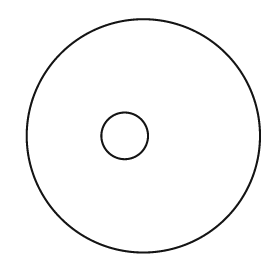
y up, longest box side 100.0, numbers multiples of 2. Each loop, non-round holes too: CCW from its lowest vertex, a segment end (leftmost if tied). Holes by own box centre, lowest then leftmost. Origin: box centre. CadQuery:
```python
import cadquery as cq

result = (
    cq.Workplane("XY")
    .moveTo(0.0, 0.0)
    .circle(50.0)
    .moveTo(-8.0, 0.0)
    .circle(10.0)
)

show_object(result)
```